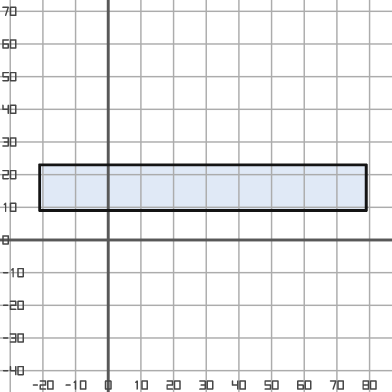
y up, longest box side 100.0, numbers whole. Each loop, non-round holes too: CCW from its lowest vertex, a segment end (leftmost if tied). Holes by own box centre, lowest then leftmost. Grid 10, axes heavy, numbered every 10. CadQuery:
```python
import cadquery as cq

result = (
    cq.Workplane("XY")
    .moveTo(-21.0, 9.0)
    .lineTo(79.0, 9.0)
    .lineTo(79.0, 23.0)
    .lineTo(-21.0, 23.0)
    .close()
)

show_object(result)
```